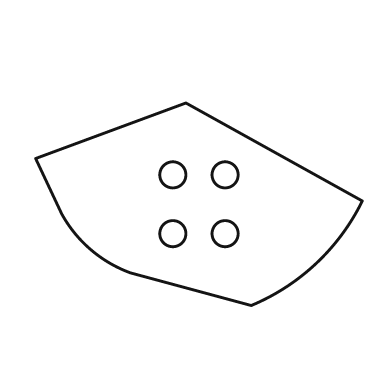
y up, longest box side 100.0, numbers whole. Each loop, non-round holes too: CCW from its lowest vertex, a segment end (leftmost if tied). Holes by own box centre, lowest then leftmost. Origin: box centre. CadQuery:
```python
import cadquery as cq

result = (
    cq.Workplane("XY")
    .moveTo(16.0, -31.0)
    .threePointArc((36.0, -18.0), (50.0, 1.0))
    .lineTo(-4.0, 31.0)
    .lineTo(-50.0, 14.0)
    .lineTo(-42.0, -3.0)
    .threePointArc((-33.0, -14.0), (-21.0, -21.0))
    .close()
    .moveTo(-8.0, -9.0)
    .circle(4.0)
    .moveTo(8.0, -9.0)
    .circle(4.0)
    .moveTo(-8.0, 9.0)
    .circle(4.0)
    .moveTo(8.0, 9.0)
    .circle(4.0)
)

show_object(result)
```